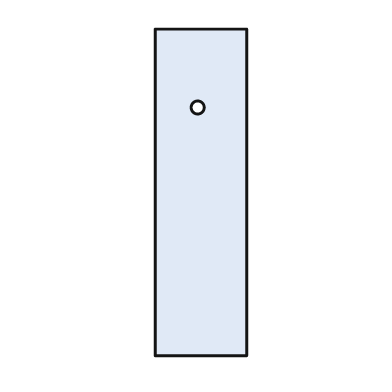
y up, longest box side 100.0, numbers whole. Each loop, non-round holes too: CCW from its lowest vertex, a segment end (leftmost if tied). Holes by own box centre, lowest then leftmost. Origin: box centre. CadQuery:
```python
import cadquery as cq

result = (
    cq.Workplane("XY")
    .moveTo(-14.0, -50.0)
    .lineTo(14.0, -50.0)
    .lineTo(14.0, 50.0)
    .lineTo(-14.0, 50.0)
    .close()
    .moveTo(-1.0, 26.0)
    .circle(2.0)
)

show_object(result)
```